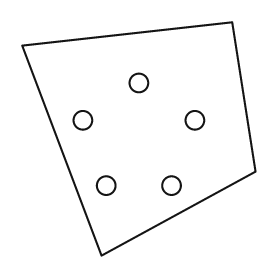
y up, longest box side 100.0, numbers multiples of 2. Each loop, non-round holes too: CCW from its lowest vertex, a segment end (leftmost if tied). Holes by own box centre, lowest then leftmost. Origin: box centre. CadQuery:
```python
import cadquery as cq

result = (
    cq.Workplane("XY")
    .moveTo(-16.0, -50.0)
    .lineTo(50.0, -14.0)
    .lineTo(40.0, 50.0)
    .lineTo(-50.0, 40.0)
    .close()
    .moveTo(-14.0, -20.0)
    .circle(4.0)
    .moveTo(14.0, -20.0)
    .circle(4.0)
    .moveTo(-24.0, 8.0)
    .circle(4.0)
    .moveTo(24.0, 8.0)
    .circle(4.0)
    .moveTo(0.0, 24.0)
    .circle(4.0)
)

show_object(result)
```